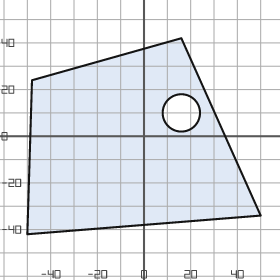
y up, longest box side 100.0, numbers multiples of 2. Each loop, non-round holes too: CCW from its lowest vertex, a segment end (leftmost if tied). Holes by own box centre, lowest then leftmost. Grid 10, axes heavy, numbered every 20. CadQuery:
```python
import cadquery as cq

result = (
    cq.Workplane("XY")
    .moveTo(-50.0, -42.0)
    .lineTo(50.0, -34.0)
    .lineTo(16.0, 42.0)
    .lineTo(-48.0, 24.0)
    .close()
    .moveTo(16.0, 10.0)
    .circle(8.0)
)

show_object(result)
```